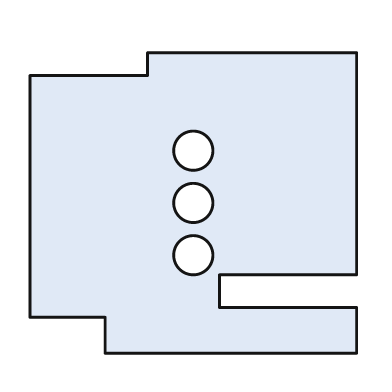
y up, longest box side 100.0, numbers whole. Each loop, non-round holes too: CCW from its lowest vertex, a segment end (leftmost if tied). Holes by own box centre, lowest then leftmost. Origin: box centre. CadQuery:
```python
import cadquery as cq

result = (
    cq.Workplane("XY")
    .moveTo(-27.0, -46.0)
    .lineTo(50.0, -46.0)
    .lineTo(50.0, -32.0)
    .lineTo(8.0, -32.0)
    .lineTo(8.0, -22.0)
    .lineTo(50.0, -22.0)
    .lineTo(50.0, 46.0)
    .lineTo(-14.0, 46.0)
    .lineTo(-14.0, 39.0)
    .lineTo(-50.0, 39.0)
    .lineTo(-50.0, -35.0)
    .lineTo(-27.0, -35.0)
    .close()
    .moveTo(0.0, -16.0)
    .circle(6.0)
    .moveTo(0.0, 0.0)
    .circle(6.0)
    .moveTo(0.0, 16.0)
    .circle(6.0)
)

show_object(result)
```